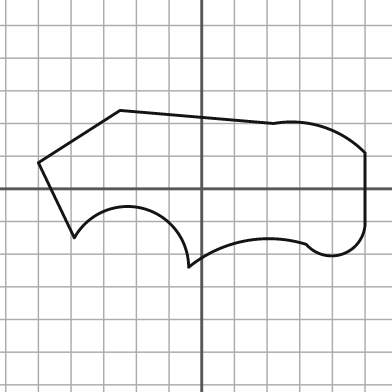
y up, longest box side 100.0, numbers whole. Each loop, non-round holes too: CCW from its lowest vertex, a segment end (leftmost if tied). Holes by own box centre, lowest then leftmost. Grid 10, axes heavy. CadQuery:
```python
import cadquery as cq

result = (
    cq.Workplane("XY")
    .moveTo(-4.0, -24.0)
    .threePointArc((13.0, -16.0), (32.0, -17.0))
    .threePointArc((43.0, -20.0), (50.0, -11.0))
    .lineTo(50.0, 11.0)
    .threePointArc((37.0, 19.0), (22.0, 20.0))
    .lineTo(-25.0, 24.0)
    .lineTo(-50.0, 8.0)
    .lineTo(-39.0, -15.0)
    .threePointArc((-18.0, -6.0), (-4.0, -24.0))
    .close()
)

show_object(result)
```